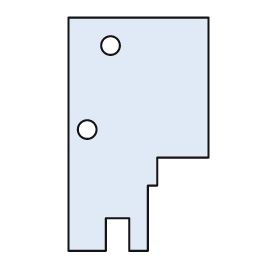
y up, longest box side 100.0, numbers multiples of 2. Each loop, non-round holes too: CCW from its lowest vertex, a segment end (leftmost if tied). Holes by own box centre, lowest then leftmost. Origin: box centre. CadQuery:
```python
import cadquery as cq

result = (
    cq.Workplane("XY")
    .moveTo(-30.0, -50.0)
    .lineTo(-14.0, -50.0)
    .lineTo(-14.0, -36.0)
    .lineTo(-4.0, -36.0)
    .lineTo(-4.0, -50.0)
    .lineTo(4.0, -50.0)
    .lineTo(4.0, -22.0)
    .lineTo(8.0, -22.0)
    .lineTo(8.0, -10.0)
    .lineTo(30.0, -10.0)
    .lineTo(30.0, 50.0)
    .lineTo(-30.0, 50.0)
    .close()
    .moveTo(-22.0, 2.0)
    .circle(4.0)
    .moveTo(-12.0, 38.0)
    .circle(4.0)
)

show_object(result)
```